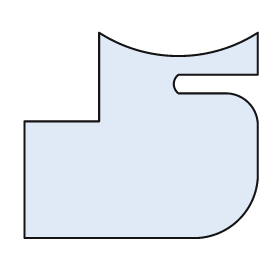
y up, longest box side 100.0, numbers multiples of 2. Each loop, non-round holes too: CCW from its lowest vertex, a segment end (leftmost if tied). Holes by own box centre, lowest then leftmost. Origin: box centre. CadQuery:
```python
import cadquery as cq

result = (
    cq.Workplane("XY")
    .moveTo(-50.0, -44.0)
    .lineTo(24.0, -44.0)
    .threePointArc((42.0, -36.0), (50.0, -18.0))
    .lineTo(50.0, 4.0)
    .threePointArc((46.0, 14.0), (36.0, 18.0))
    .lineTo(16.0, 18.0)
    .threePointArc((14.0, 22.0), (16.0, 26.0))
    .lineTo(50.0, 26.0)
    .lineTo(50.0, 44.0)
    .threePointArc((16.0, 34.0), (-18.0, 44.0))
    .lineTo(-18.0, 6.0)
    .lineTo(-50.0, 6.0)
    .close()
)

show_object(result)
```